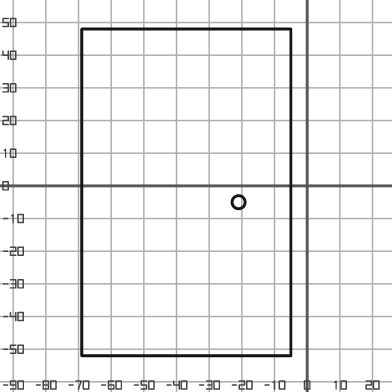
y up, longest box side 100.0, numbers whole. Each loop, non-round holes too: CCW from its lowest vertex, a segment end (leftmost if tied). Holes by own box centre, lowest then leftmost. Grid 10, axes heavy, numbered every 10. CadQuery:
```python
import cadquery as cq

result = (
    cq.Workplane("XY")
    .moveTo(-69.0, -52.0)
    .lineTo(-5.0, -52.0)
    .lineTo(-5.0, 48.0)
    .lineTo(-69.0, 48.0)
    .close()
    .moveTo(-21.0, -5.0)
    .circle(2.0)
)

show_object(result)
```